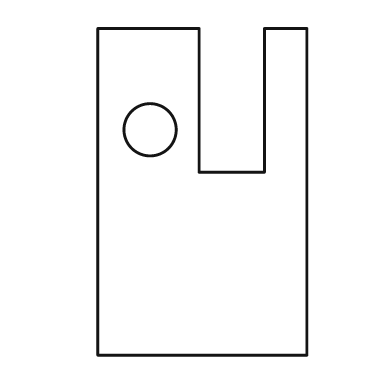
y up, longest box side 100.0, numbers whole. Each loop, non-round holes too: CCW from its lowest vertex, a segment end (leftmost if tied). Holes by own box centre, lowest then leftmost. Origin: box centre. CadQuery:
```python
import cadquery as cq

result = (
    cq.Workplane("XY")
    .moveTo(-32.0, -50.0)
    .lineTo(32.0, -50.0)
    .lineTo(32.0, 50.0)
    .lineTo(19.0, 50.0)
    .lineTo(19.0, 6.0)
    .lineTo(-1.0, 6.0)
    .lineTo(-1.0, 50.0)
    .lineTo(-32.0, 50.0)
    .close()
    .moveTo(-16.0, 19.0)
    .circle(8.0)
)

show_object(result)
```